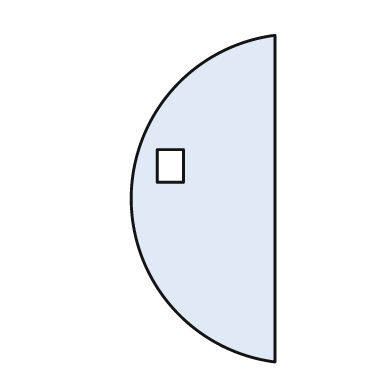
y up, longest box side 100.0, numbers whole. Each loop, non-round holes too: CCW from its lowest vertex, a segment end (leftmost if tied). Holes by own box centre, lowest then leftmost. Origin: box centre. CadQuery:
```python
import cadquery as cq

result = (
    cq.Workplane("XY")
    .moveTo(22.0, -50.0)
    .lineTo(22.0, 50.0)
    .threePointArc((-22.0, 0.0), (22.0, -50.0))
    .close()
    .moveTo(-14.0, 5.0)
    .lineTo(-6.0, 5.0)
    .lineTo(-6.0, 15.0)
    .lineTo(-14.0, 15.0)
    .close()
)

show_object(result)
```